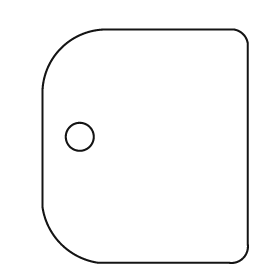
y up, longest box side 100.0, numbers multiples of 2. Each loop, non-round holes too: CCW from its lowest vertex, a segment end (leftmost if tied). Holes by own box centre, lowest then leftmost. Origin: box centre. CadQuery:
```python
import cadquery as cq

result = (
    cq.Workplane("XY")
    .moveTo(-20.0, -50.0)
    .lineTo(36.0, -50.0)
    .threePointArc((42.0, -48.0), (44.0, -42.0))
    .lineTo(44.0, 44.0)
    .threePointArc((42.0, 48.0), (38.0, 50.0))
    .lineTo(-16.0, 50.0)
    .threePointArc((-36.0, 42.0), (-44.0, 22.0))
    .lineTo(-44.0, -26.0)
    .threePointArc((-36.0, -42.0), (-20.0, -50.0))
    .close()
    .moveTo(-28.0, 4.0)
    .circle(6.0)
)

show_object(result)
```